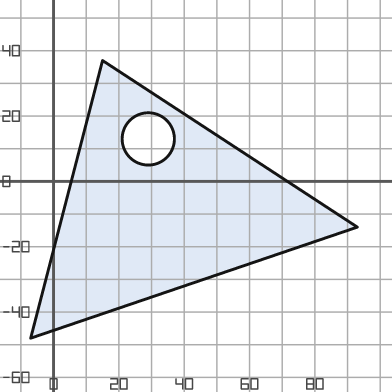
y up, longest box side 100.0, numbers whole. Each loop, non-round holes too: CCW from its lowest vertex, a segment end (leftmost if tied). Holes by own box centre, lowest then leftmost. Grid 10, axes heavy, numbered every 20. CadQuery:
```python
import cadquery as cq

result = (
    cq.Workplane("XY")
    .moveTo(-7.0, -48.0)
    .lineTo(93.0, -14.0)
    .lineTo(15.0, 37.0)
    .close()
    .moveTo(29.0, 13.0)
    .circle(8.0)
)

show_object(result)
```